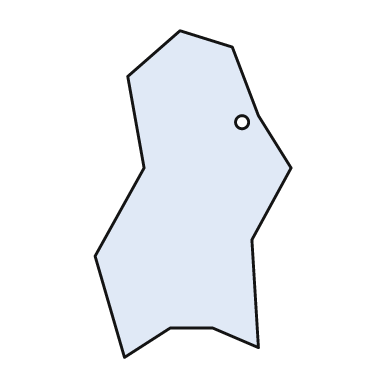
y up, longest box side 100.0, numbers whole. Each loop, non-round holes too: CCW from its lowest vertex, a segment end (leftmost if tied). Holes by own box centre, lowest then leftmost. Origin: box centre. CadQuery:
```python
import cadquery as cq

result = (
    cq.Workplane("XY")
    .moveTo(-21.0, -50.0)
    .lineTo(-7.0, -41.0)
    .lineTo(6.0, -41.0)
    .lineTo(20.0, -47.0)
    .lineTo(18.0, -14.0)
    .lineTo(30.0, 8.0)
    .lineTo(20.0, 24.0)
    .lineTo(12.0, 45.0)
    .lineTo(-4.0, 50.0)
    .lineTo(-20.0, 36.0)
    .lineTo(-15.0, 8.0)
    .lineTo(-30.0, -19.0)
    .close()
    .moveTo(15.0, 22.0)
    .circle(2.0)
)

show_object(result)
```